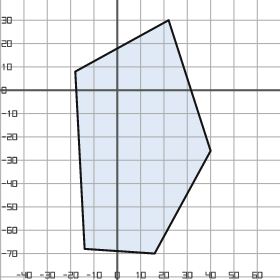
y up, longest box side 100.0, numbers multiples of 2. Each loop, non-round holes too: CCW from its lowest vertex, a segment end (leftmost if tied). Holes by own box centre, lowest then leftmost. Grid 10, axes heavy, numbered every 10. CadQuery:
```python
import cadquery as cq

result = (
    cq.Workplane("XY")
    .moveTo(16.0, -70.0)
    .lineTo(40.0, -26.0)
    .lineTo(22.0, 30.0)
    .lineTo(-18.0, 8.0)
    .lineTo(-14.0, -68.0)
    .close()
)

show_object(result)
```